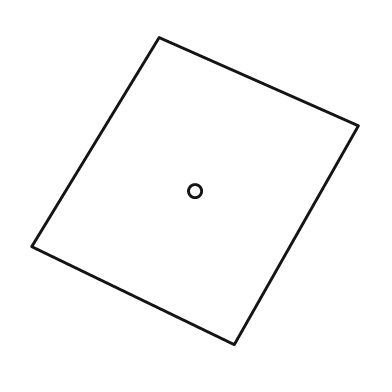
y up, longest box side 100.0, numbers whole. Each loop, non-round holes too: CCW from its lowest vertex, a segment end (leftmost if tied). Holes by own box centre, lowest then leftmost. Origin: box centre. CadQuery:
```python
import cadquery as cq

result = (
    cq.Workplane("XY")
    .moveTo(12.0, -47.0)
    .lineTo(50.0, 20.0)
    .lineTo(-11.0, 47.0)
    .lineTo(-50.0, -17.0)
    .close()
    .moveTo(0.0, 0.0)
    .circle(2.0)
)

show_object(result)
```